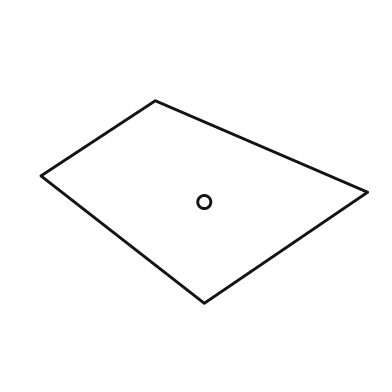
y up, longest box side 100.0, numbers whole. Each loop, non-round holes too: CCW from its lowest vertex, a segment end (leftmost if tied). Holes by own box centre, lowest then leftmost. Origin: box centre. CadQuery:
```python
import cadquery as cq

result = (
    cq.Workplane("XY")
    .moveTo(0.0, -31.0)
    .lineTo(50.0, 3.0)
    .lineTo(-15.0, 31.0)
    .lineTo(-50.0, 8.0)
    .close()
    .moveTo(0.0, 0.0)
    .circle(2.0)
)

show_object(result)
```